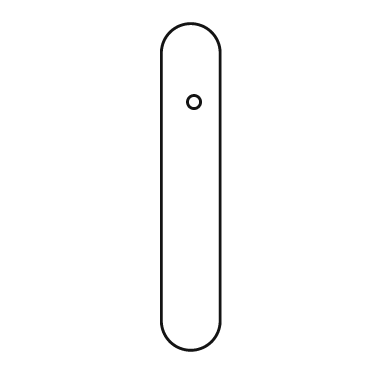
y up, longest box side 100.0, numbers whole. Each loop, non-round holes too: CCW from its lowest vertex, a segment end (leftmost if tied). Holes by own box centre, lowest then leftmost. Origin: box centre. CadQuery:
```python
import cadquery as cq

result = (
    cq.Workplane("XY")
    .moveTo(-9.0, -41.0)
    .threePointArc((0.0, -50.0), (9.0, -41.0))
    .lineTo(9.0, 41.0)
    .threePointArc((0.0, 50.0), (-9.0, 41.0))
    .close()
    .moveTo(1.0, 26.0)
    .circle(2.0)
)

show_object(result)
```